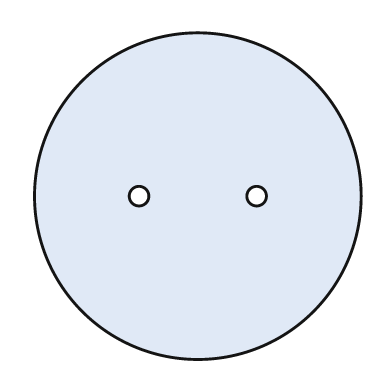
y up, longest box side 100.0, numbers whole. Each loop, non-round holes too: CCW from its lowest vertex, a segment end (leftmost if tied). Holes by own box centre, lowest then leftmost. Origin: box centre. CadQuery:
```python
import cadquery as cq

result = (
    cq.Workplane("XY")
    .moveTo(0.0, 0.0)
    .circle(50.0)
    .moveTo(-18.0, 0.0)
    .circle(3.0)
    .moveTo(18.0, 0.0)
    .circle(3.0)
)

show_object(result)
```